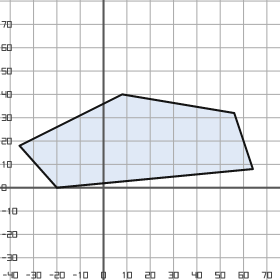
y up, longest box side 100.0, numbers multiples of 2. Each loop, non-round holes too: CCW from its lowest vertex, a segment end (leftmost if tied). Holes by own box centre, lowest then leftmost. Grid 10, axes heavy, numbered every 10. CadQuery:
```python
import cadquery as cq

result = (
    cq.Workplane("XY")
    .moveTo(-20.0, 0.0)
    .lineTo(64.0, 8.0)
    .lineTo(56.0, 32.0)
    .lineTo(8.0, 40.0)
    .lineTo(-36.0, 18.0)
    .close()
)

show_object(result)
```